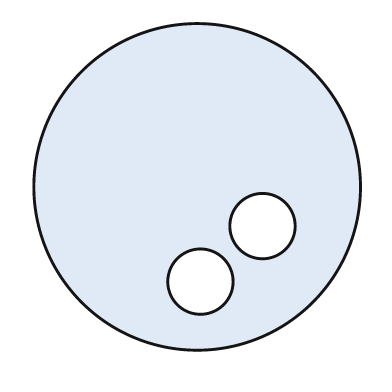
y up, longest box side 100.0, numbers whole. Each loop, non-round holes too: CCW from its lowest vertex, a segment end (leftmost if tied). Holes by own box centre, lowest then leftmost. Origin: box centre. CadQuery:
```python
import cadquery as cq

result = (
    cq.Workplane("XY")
    .moveTo(0.0, 0.0)
    .circle(50.0)
    .moveTo(1.0, -29.0)
    .circle(10.0)
    .moveTo(20.0, -12.0)
    .circle(10.0)
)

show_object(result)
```